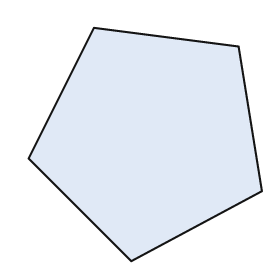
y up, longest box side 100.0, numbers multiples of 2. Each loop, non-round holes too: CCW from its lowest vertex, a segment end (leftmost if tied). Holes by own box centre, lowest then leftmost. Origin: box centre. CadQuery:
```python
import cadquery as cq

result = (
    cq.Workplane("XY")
    .moveTo(-6.0, -50.0)
    .lineTo(50.0, -20.0)
    .lineTo(40.0, 42.0)
    .lineTo(-22.0, 50.0)
    .lineTo(-50.0, -6.0)
    .close()
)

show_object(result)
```